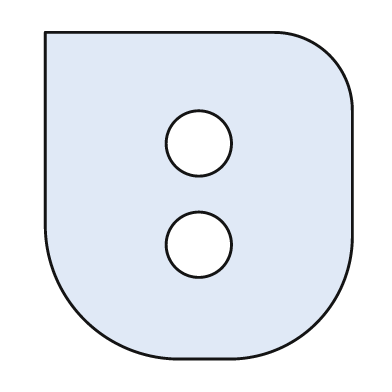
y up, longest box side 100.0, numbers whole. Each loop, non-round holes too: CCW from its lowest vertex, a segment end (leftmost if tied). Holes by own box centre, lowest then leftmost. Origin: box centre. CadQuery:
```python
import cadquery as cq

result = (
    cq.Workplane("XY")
    .moveTo(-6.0, -50.0)
    .lineTo(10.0, -50.0)
    .threePointArc((36.0, -39.0), (47.0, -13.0))
    .lineTo(47.0, 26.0)
    .threePointArc((40.0, 43.0), (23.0, 50.0))
    .lineTo(-47.0, 50.0)
    .lineTo(-47.0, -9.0)
    .threePointArc((-35.0, -38.0), (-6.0, -50.0))
    .close()
    .moveTo(0.0, -15.0)
    .circle(10.0)
    .moveTo(0.0, 16.0)
    .circle(10.0)
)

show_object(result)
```